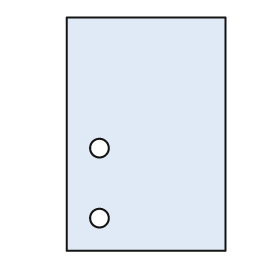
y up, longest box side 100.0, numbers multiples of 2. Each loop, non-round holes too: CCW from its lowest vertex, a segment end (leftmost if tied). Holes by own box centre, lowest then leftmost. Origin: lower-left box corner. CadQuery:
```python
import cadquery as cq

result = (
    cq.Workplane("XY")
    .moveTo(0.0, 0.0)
    .lineTo(68.0, 0.0)
    .lineTo(68.0, 100.0)
    .lineTo(0.0, 100.0)
    .close()
    .moveTo(14.0, 14.0)
    .circle(4.0)
    .moveTo(14.0, 44.0)
    .circle(4.0)
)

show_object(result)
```